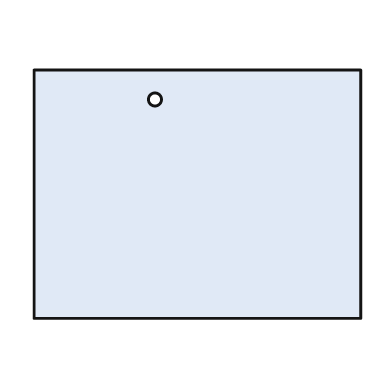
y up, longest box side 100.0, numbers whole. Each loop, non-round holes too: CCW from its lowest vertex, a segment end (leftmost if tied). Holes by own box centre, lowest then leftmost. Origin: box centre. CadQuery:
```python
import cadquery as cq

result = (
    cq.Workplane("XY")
    .moveTo(-50.0, -38.0)
    .lineTo(50.0, -38.0)
    .lineTo(50.0, 38.0)
    .lineTo(-50.0, 38.0)
    .close()
    .moveTo(-13.0, 29.0)
    .circle(2.0)
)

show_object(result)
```